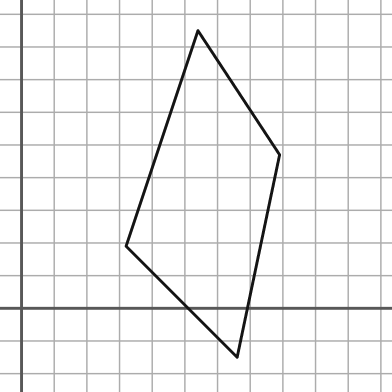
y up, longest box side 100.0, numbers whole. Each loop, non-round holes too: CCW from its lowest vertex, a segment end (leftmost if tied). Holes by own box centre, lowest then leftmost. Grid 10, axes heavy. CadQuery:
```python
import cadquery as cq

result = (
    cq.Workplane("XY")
    .moveTo(66.0, -15.0)
    .lineTo(79.0, 47.0)
    .lineTo(54.0, 85.0)
    .lineTo(32.0, 19.0)
    .close()
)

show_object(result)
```